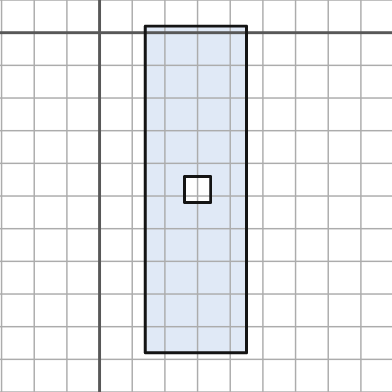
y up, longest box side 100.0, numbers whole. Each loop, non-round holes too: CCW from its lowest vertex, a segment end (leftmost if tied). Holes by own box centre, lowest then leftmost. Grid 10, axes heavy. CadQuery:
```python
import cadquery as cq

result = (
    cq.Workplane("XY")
    .moveTo(14.0, -98.0)
    .lineTo(45.0, -98.0)
    .lineTo(45.0, 2.0)
    .lineTo(14.0, 2.0)
    .close()
    .moveTo(26.0, -52.0)
    .lineTo(34.0, -52.0)
    .lineTo(34.0, -44.0)
    .lineTo(26.0, -44.0)
    .close()
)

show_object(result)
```